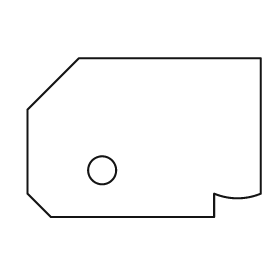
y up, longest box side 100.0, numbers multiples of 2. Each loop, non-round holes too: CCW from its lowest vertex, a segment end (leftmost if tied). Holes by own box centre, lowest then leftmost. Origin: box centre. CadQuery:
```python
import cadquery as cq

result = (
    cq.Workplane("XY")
    .moveTo(-40.0, -34.0)
    .lineTo(30.0, -34.0)
    .lineTo(30.0, -24.0)
    .threePointArc((40.0, -26.0), (50.0, -24.0))
    .lineTo(50.0, 34.0)
    .lineTo(-28.0, 34.0)
    .lineTo(-50.0, 12.0)
    .lineTo(-50.0, -24.0)
    .close()
    .moveTo(-18.0, -14.0)
    .circle(6.0)
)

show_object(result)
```